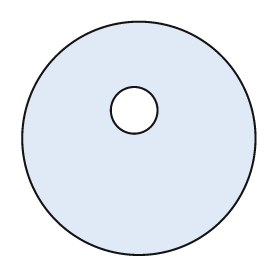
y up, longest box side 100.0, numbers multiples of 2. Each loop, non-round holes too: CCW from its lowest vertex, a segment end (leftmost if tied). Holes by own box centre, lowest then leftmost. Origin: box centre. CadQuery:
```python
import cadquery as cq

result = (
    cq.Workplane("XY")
    .moveTo(0.0, 0.0)
    .circle(50.0)
    .moveTo(-2.0, 12.0)
    .circle(10.0)
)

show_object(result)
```